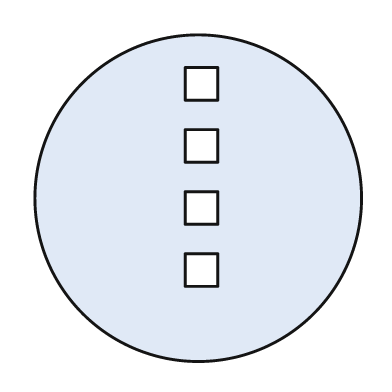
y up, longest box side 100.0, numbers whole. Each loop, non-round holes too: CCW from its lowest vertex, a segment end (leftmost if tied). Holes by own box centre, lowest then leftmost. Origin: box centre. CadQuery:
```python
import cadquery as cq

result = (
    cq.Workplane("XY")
    .moveTo(0.0, 0.0)
    .circle(50.0)
    .moveTo(-4.0, -27.0)
    .lineTo(6.0, -27.0)
    .lineTo(6.0, -17.0)
    .lineTo(-4.0, -17.0)
    .close()
    .moveTo(-4.0, -8.0)
    .lineTo(6.0, -8.0)
    .lineTo(6.0, 2.0)
    .lineTo(-4.0, 2.0)
    .close()
    .moveTo(-4.0, 11.0)
    .lineTo(6.0, 11.0)
    .lineTo(6.0, 21.0)
    .lineTo(-4.0, 21.0)
    .close()
    .moveTo(-4.0, 30.0)
    .lineTo(6.0, 30.0)
    .lineTo(6.0, 40.0)
    .lineTo(-4.0, 40.0)
    .close()
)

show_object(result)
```